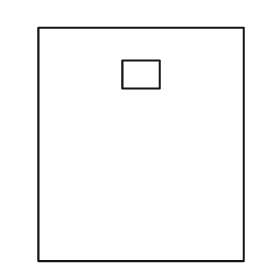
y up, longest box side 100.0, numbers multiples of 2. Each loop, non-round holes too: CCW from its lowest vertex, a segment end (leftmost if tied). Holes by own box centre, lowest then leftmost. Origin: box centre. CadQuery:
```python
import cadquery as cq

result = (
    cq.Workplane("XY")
    .moveTo(-44.0, -50.0)
    .lineTo(44.0, -50.0)
    .lineTo(44.0, 50.0)
    .lineTo(-44.0, 50.0)
    .close()
    .moveTo(-8.0, 24.0)
    .lineTo(8.0, 24.0)
    .lineTo(8.0, 36.0)
    .lineTo(-8.0, 36.0)
    .close()
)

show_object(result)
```